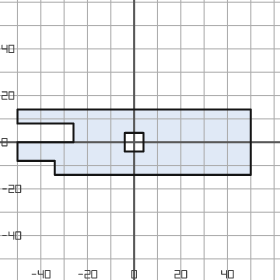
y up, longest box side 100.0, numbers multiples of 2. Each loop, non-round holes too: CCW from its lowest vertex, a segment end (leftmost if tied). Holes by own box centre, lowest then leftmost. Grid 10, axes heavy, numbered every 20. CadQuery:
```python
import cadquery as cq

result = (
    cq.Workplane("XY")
    .moveTo(-34.0, -14.0)
    .lineTo(50.0, -14.0)
    .lineTo(50.0, 14.0)
    .lineTo(-50.0, 14.0)
    .lineTo(-50.0, 8.0)
    .lineTo(-26.0, 8.0)
    .lineTo(-26.0, 0.0)
    .lineTo(-50.0, 0.0)
    .lineTo(-50.0, -8.0)
    .lineTo(-34.0, -8.0)
    .close()
    .moveTo(-4.0, -4.0)
    .lineTo(4.0, -4.0)
    .lineTo(4.0, 4.0)
    .lineTo(-4.0, 4.0)
    .close()
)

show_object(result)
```